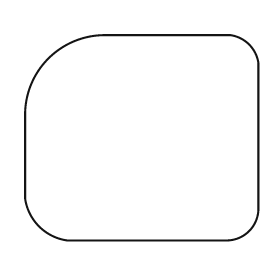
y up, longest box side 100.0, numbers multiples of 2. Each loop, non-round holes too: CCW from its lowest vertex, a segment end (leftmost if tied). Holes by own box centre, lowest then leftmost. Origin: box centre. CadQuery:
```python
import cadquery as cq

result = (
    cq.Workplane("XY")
    .moveTo(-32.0, -44.0)
    .lineTo(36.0, -44.0)
    .threePointArc((46.0, -40.0), (50.0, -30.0))
    .lineTo(50.0, 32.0)
    .threePointArc((46.0, 40.0), (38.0, 44.0))
    .lineTo(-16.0, 44.0)
    .threePointArc((-40.0, 34.0), (-50.0, 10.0))
    .lineTo(-50.0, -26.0)
    .threePointArc((-44.0, -38.0), (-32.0, -44.0))
    .close()
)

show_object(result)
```